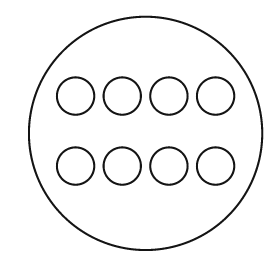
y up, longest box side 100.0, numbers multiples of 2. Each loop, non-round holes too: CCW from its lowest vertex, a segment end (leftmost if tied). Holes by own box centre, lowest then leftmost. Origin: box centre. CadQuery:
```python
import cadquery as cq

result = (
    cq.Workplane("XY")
    .moveTo(0.0, 0.0)
    .circle(50.0)
    .moveTo(-30.0, -14.0)
    .circle(8.0)
    .moveTo(-10.0, -14.0)
    .circle(8.0)
    .moveTo(10.0, -14.0)
    .circle(8.0)
    .moveTo(30.0, -14.0)
    .circle(8.0)
    .moveTo(-30.0, 16.0)
    .circle(8.0)
    .moveTo(-10.0, 16.0)
    .circle(8.0)
    .moveTo(10.0, 16.0)
    .circle(8.0)
    .moveTo(30.0, 16.0)
    .circle(8.0)
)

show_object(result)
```